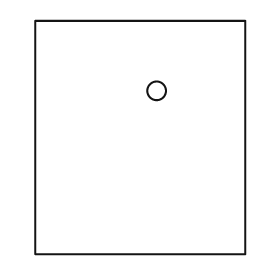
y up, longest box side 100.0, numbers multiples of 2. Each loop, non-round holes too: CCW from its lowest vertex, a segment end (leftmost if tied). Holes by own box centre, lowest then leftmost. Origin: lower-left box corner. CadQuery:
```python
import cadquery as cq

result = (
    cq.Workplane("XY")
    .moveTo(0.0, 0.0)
    .lineTo(90.0, 0.0)
    .lineTo(90.0, 100.0)
    .lineTo(0.0, 100.0)
    .close()
    .moveTo(52.0, 70.0)
    .circle(4.0)
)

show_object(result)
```